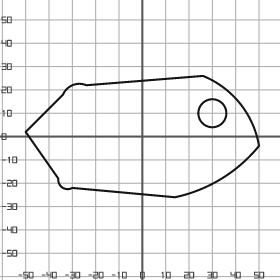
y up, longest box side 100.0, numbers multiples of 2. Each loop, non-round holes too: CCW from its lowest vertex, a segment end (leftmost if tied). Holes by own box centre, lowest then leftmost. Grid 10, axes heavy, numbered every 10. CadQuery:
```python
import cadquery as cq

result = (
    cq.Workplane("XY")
    .moveTo(14.0, -26.0)
    .threePointArc((34.0, -18.0), (50.0, -4.0))
    .threePointArc((42.0, 14.0), (26.0, 26.0))
    .lineTo(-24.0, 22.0)
    .threePointArc((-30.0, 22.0), (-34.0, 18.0))
    .lineTo(-50.0, 2.0)
    .lineTo(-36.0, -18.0)
    .threePointArc((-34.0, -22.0), (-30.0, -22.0))
    .close()
    .moveTo(30.0, 10.0)
    .circle(6.0)
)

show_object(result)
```